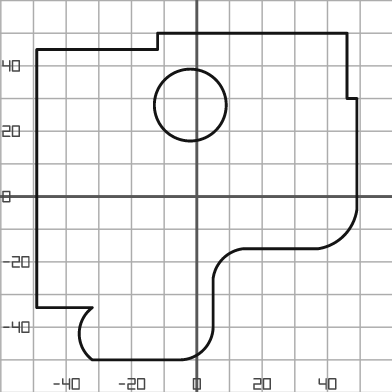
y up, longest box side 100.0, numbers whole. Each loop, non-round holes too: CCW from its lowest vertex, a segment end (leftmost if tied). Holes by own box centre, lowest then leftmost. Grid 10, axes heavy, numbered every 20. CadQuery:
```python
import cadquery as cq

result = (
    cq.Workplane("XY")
    .moveTo(-32.0, -50.0)
    .lineTo(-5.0, -50.0)
    .threePointArc((2.0, -47.0), (5.0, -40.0))
    .lineTo(5.0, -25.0)
    .threePointArc((8.0, -19.0), (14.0, -16.0))
    .lineTo(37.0, -16.0)
    .threePointArc((45.0, -12.0), (49.0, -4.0))
    .lineTo(49.0, 30.0)
    .lineTo(46.0, 30.0)
    .lineTo(46.0, 50.0)
    .lineTo(-12.0, 50.0)
    .lineTo(-12.0, 45.0)
    .lineTo(-49.0, 45.0)
    .lineTo(-49.0, -34.0)
    .lineTo(-32.0, -34.0)
    .threePointArc((-36.0, -42.0), (-32.0, -50.0))
    .close()
    .moveTo(-2.0, 28.0)
    .circle(11.0)
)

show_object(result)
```